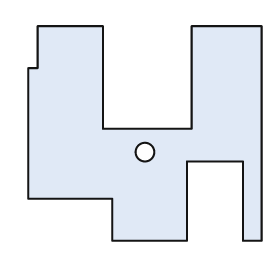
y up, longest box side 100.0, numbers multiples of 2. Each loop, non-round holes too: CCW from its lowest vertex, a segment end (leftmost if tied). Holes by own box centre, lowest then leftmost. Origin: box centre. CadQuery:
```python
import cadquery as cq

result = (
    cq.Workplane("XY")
    .moveTo(-14.0, -46.0)
    .lineTo(18.0, -46.0)
    .lineTo(18.0, -12.0)
    .lineTo(42.0, -12.0)
    .lineTo(42.0, -46.0)
    .lineTo(50.0, -46.0)
    .lineTo(50.0, 46.0)
    .lineTo(20.0, 46.0)
    .lineTo(20.0, 2.0)
    .lineTo(-18.0, 2.0)
    .lineTo(-18.0, 46.0)
    .lineTo(-46.0, 46.0)
    .lineTo(-46.0, 28.0)
    .lineTo(-50.0, 28.0)
    .lineTo(-50.0, -28.0)
    .lineTo(-14.0, -28.0)
    .close()
    .moveTo(0.0, -8.0)
    .circle(4.0)
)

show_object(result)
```